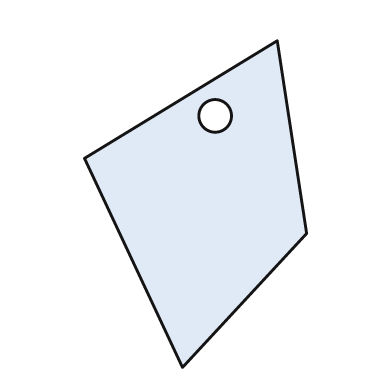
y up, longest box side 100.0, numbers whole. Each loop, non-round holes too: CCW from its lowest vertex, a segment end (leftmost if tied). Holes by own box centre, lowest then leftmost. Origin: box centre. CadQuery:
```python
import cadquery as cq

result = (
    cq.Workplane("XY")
    .moveTo(-4.0, -50.0)
    .lineTo(34.0, -9.0)
    .lineTo(25.0, 50.0)
    .lineTo(-34.0, 14.0)
    .close()
    .moveTo(6.0, 27.0)
    .circle(5.0)
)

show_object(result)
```